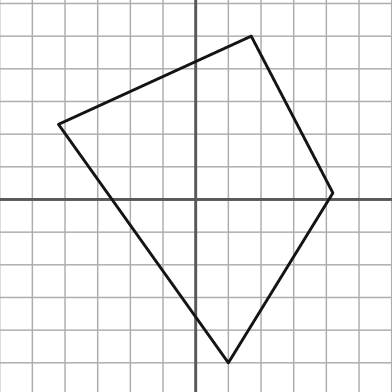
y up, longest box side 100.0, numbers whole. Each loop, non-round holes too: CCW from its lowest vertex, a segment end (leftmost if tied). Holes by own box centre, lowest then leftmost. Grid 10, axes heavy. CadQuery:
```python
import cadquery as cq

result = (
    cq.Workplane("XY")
    .moveTo(10.0, -50.0)
    .lineTo(42.0, 2.0)
    .lineTo(17.0, 50.0)
    .lineTo(-42.0, 23.0)
    .close()
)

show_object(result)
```